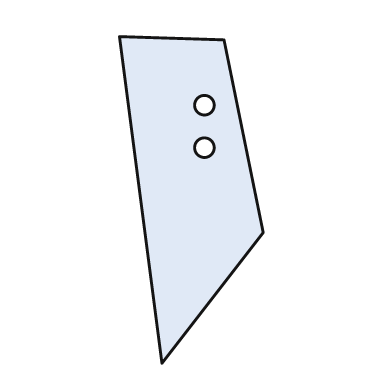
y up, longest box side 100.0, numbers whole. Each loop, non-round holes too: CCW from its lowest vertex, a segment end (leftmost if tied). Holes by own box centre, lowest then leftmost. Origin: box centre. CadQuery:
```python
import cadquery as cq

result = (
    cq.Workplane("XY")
    .moveTo(-9.0, -50.0)
    .lineTo(22.0, -10.0)
    .lineTo(10.0, 49.0)
    .lineTo(-22.0, 50.0)
    .close()
    .moveTo(4.0, 16.0)
    .circle(3.0)
    .moveTo(4.0, 29.0)
    .circle(3.0)
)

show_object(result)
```